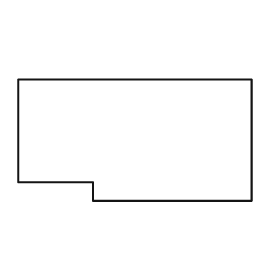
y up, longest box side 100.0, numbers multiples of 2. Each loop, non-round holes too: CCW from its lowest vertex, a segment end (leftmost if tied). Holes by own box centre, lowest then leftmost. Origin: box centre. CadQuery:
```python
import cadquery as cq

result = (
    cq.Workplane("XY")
    .moveTo(-18.0, -26.0)
    .lineTo(50.0, -26.0)
    .lineTo(50.0, 26.0)
    .lineTo(-50.0, 26.0)
    .lineTo(-50.0, -18.0)
    .lineTo(-18.0, -18.0)
    .close()
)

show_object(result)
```